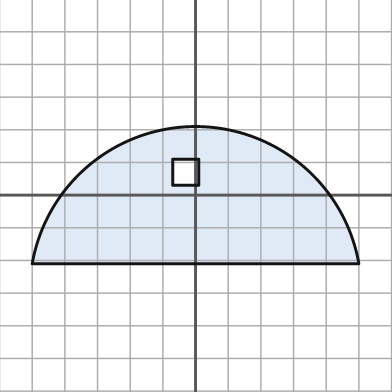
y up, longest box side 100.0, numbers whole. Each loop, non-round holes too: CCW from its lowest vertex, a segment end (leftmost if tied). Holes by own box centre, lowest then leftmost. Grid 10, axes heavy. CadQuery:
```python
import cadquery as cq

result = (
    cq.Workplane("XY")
    .moveTo(-50.0, -21.0)
    .lineTo(50.0, -21.0)
    .threePointArc((0.0, 21.0), (-50.0, -21.0))
    .close()
    .moveTo(-7.0, 3.0)
    .lineTo(1.0, 3.0)
    .lineTo(1.0, 11.0)
    .lineTo(-7.0, 11.0)
    .close()
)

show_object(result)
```